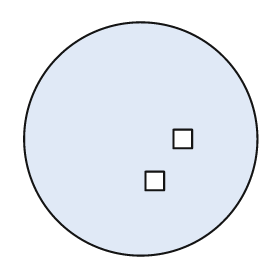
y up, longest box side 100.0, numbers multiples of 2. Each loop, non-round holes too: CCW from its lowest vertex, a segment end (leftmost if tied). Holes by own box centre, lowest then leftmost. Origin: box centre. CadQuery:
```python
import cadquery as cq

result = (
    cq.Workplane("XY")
    .moveTo(0.0, 0.0)
    .circle(50.0)
    .moveTo(2.0, -22.0)
    .lineTo(10.0, -22.0)
    .lineTo(10.0, -14.0)
    .lineTo(2.0, -14.0)
    .close()
    .moveTo(14.0, -4.0)
    .lineTo(22.0, -4.0)
    .lineTo(22.0, 4.0)
    .lineTo(14.0, 4.0)
    .close()
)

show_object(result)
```